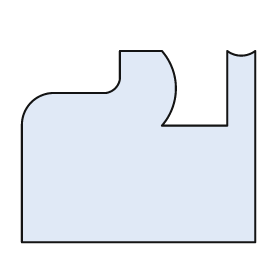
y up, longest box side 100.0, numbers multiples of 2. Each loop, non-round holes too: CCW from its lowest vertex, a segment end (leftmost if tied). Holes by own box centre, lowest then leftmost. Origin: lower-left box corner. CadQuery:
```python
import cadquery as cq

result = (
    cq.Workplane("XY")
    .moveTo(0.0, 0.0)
    .lineTo(100.0, 0.0)
    .lineTo(100.0, 82.0)
    .threePointArc((94.0, 80.0), (88.0, 82.0))
    .lineTo(88.0, 50.0)
    .lineTo(60.0, 50.0)
    .threePointArc((66.0, 66.0), (60.0, 82.0))
    .lineTo(42.0, 82.0)
    .lineTo(42.0, 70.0)
    .threePointArc((40.0, 66.0), (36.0, 64.0))
    .lineTo(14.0, 64.0)
    .threePointArc((4.0, 60.0), (0.0, 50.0))
    .close()
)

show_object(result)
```